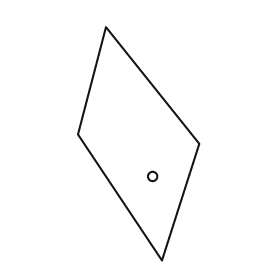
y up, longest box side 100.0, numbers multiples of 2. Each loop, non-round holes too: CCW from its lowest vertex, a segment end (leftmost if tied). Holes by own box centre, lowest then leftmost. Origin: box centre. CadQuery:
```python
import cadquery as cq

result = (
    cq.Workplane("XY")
    .moveTo(10.0, -50.0)
    .lineTo(26.0, 0.0)
    .lineTo(-14.0, 50.0)
    .lineTo(-26.0, 4.0)
    .close()
    .moveTo(6.0, -14.0)
    .circle(2.0)
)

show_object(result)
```